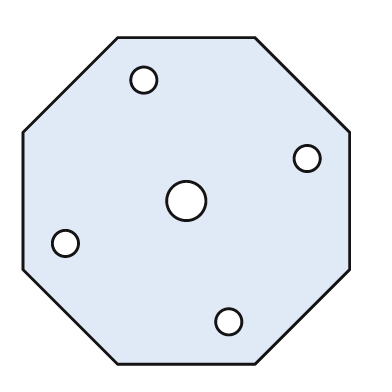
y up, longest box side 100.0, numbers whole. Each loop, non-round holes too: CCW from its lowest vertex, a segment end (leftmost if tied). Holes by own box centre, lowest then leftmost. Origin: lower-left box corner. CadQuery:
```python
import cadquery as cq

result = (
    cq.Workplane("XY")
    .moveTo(29.0, 0.0)
    .lineTo(71.0, 0.0)
    .lineTo(100.0, 29.0)
    .lineTo(100.0, 71.0)
    .lineTo(71.0, 100.0)
    .lineTo(29.0, 100.0)
    .lineTo(0.0, 71.0)
    .lineTo(0.0, 29.0)
    .close()
    .moveTo(63.0, 13.0)
    .circle(4.0)
    .moveTo(13.0, 37.0)
    .circle(4.0)
    .moveTo(50.0, 50.0)
    .circle(6.0)
    .moveTo(87.0, 63.0)
    .circle(4.0)
    .moveTo(37.0, 87.0)
    .circle(4.0)
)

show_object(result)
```